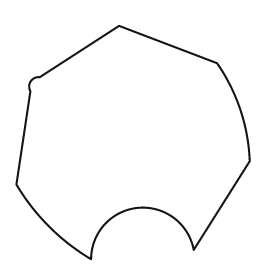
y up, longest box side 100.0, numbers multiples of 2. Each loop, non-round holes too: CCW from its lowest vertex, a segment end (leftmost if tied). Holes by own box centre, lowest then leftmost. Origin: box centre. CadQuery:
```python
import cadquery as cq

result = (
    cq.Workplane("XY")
    .moveTo(-18.0, -50.0)
    .threePointArc((2.0, -28.0), (26.0, -46.0))
    .lineTo(50.0, -8.0)
    .threePointArc((46.0, 14.0), (36.0, 34.0))
    .lineTo(-6.0, 50.0)
    .lineTo(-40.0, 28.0)
    .threePointArc((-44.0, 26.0), (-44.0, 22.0))
    .lineTo(-50.0, -18.0)
    .threePointArc((-36.0, -36.0), (-18.0, -50.0))
    .close()
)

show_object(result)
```